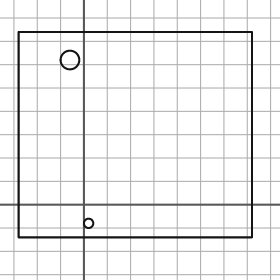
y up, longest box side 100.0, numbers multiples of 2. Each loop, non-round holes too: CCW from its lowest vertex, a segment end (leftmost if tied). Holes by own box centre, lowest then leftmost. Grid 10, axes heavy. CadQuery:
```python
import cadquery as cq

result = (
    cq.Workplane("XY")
    .moveTo(-28.0, -14.0)
    .lineTo(72.0, -14.0)
    .lineTo(72.0, 74.0)
    .lineTo(-28.0, 74.0)
    .close()
    .moveTo(2.0, -8.0)
    .circle(2.0)
    .moveTo(-6.0, 62.0)
    .circle(4.0)
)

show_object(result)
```